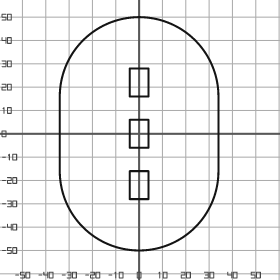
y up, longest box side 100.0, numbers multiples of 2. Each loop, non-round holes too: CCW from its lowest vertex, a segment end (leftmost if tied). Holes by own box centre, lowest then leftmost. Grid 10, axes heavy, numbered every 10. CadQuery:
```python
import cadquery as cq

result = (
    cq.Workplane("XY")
    .moveTo(-34.0, -16.0)
    .threePointArc((0.0, -50.0), (34.0, -16.0))
    .lineTo(34.0, 16.0)
    .threePointArc((0.0, 50.0), (-34.0, 16.0))
    .close()
    .moveTo(-4.0, -28.0)
    .lineTo(4.0, -28.0)
    .lineTo(4.0, -16.0)
    .lineTo(-4.0, -16.0)
    .close()
    .moveTo(-4.0, -6.0)
    .lineTo(4.0, -6.0)
    .lineTo(4.0, 6.0)
    .lineTo(-4.0, 6.0)
    .close()
    .moveTo(-4.0, 16.0)
    .lineTo(4.0, 16.0)
    .lineTo(4.0, 28.0)
    .lineTo(-4.0, 28.0)
    .close()
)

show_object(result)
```